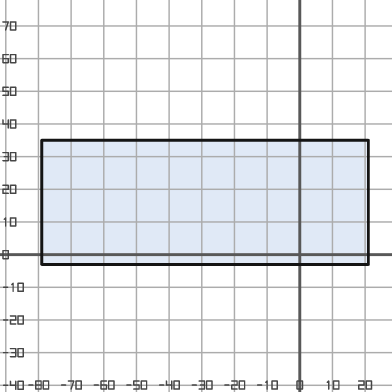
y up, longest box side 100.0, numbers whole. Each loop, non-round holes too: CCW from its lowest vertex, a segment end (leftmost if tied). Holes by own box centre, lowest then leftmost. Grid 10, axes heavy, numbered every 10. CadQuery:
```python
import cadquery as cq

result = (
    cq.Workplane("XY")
    .moveTo(-79.0, -3.0)
    .lineTo(21.0, -3.0)
    .lineTo(21.0, 35.0)
    .lineTo(-79.0, 35.0)
    .close()
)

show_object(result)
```